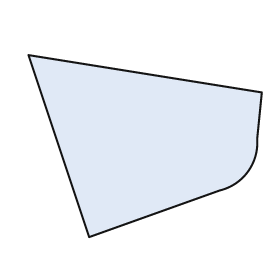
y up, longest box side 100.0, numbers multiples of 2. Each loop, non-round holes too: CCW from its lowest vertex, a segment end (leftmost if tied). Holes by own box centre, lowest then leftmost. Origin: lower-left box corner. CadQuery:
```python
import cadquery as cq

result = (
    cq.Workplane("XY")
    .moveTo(26.0, 0.0)
    .lineTo(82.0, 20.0)
    .threePointArc((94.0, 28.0), (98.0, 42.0))
    .lineTo(100.0, 62.0)
    .lineTo(0.0, 78.0)
    .close()
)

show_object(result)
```